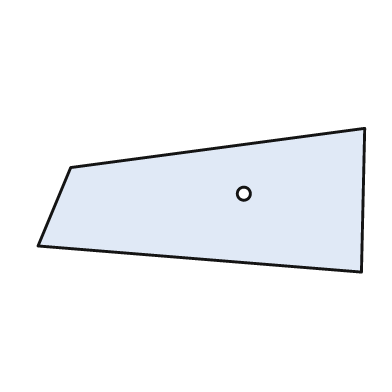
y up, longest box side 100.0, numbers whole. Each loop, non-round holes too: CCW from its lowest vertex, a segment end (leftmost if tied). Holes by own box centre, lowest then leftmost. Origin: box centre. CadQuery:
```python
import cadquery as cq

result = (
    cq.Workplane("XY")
    .moveTo(49.0, -22.0)
    .lineTo(50.0, 22.0)
    .lineTo(-40.0, 10.0)
    .lineTo(-50.0, -14.0)
    .close()
    .moveTo(13.0, 2.0)
    .circle(2.0)
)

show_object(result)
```